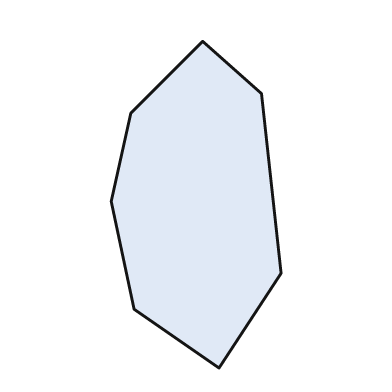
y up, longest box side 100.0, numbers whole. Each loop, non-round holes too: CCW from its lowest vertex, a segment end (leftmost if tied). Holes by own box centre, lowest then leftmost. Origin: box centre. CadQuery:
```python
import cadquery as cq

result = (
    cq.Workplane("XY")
    .moveTo(7.0, -50.0)
    .lineTo(26.0, -21.0)
    .lineTo(20.0, 34.0)
    .lineTo(2.0, 50.0)
    .lineTo(-20.0, 28.0)
    .lineTo(-26.0, 1.0)
    .lineTo(-19.0, -32.0)
    .close()
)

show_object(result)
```